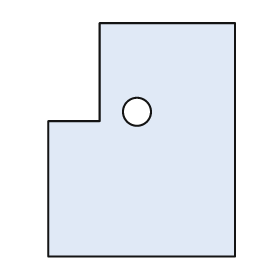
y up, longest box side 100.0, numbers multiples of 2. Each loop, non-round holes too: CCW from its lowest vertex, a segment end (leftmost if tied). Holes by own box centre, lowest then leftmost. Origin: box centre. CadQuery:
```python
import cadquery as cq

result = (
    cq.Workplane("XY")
    .moveTo(-40.0, -50.0)
    .lineTo(40.0, -50.0)
    .lineTo(40.0, 50.0)
    .lineTo(-18.0, 50.0)
    .lineTo(-18.0, 8.0)
    .lineTo(-40.0, 8.0)
    .close()
    .moveTo(-2.0, 12.0)
    .circle(6.0)
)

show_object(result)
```